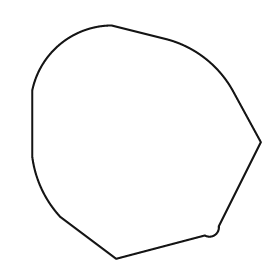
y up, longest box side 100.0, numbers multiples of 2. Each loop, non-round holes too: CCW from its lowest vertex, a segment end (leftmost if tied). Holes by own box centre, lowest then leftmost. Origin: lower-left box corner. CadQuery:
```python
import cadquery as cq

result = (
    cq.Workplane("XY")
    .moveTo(36.0, 0.0)
    .lineTo(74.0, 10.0)
    .threePointArc((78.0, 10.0), (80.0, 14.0))
    .lineTo(98.0, 50.0)
    .lineTo(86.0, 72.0)
    .threePointArc((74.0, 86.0), (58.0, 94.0))
    .lineTo(34.0, 100.0)
    .threePointArc((12.0, 92.0), (0.0, 72.0))
    .lineTo(0.0, 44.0)
    .threePointArc((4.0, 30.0), (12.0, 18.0))
    .close()
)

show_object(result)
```